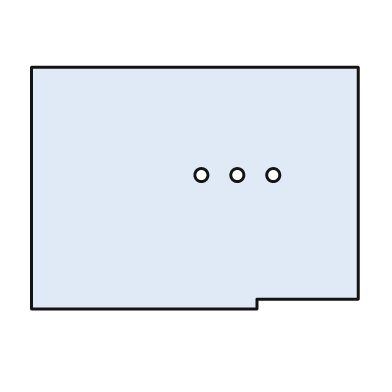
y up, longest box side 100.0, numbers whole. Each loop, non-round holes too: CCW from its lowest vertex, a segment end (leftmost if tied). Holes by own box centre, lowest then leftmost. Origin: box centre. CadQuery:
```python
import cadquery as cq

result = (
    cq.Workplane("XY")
    .moveTo(-50.0, -37.0)
    .lineTo(19.0, -37.0)
    .lineTo(19.0, -34.0)
    .lineTo(50.0, -34.0)
    .lineTo(50.0, 37.0)
    .lineTo(-50.0, 37.0)
    .close()
    .moveTo(2.0, 4.0)
    .circle(2.0)
    .moveTo(13.0, 4.0)
    .circle(2.0)
    .moveTo(24.0, 4.0)
    .circle(2.0)
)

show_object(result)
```